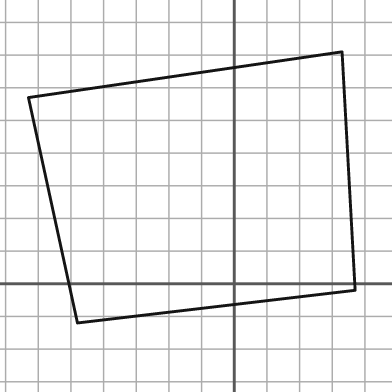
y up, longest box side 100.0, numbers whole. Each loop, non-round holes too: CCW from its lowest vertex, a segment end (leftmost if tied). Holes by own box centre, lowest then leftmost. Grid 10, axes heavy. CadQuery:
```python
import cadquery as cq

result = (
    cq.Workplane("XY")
    .moveTo(-48.0, -12.0)
    .lineTo(37.0, -2.0)
    .lineTo(33.0, 71.0)
    .lineTo(-63.0, 57.0)
    .close()
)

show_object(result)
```